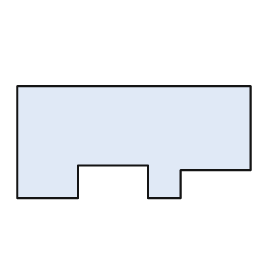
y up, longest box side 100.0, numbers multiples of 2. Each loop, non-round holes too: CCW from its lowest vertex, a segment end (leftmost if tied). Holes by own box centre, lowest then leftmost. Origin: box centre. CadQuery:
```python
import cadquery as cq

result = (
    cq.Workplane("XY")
    .moveTo(-50.0, -24.0)
    .lineTo(-24.0, -24.0)
    .lineTo(-24.0, -10.0)
    .lineTo(6.0, -10.0)
    .lineTo(6.0, -24.0)
    .lineTo(20.0, -24.0)
    .lineTo(20.0, -12.0)
    .lineTo(50.0, -12.0)
    .lineTo(50.0, 24.0)
    .lineTo(-50.0, 24.0)
    .close()
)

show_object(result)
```